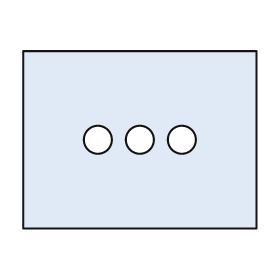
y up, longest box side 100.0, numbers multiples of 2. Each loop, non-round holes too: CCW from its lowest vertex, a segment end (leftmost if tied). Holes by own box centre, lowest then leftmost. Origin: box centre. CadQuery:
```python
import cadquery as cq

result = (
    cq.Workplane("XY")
    .moveTo(-50.0, -38.0)
    .lineTo(50.0, -38.0)
    .lineTo(50.0, 38.0)
    .lineTo(-50.0, 38.0)
    .close()
    .moveTo(-18.0, 0.0)
    .circle(6.0)
    .moveTo(0.0, 0.0)
    .circle(6.0)
    .moveTo(18.0, 0.0)
    .circle(6.0)
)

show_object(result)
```